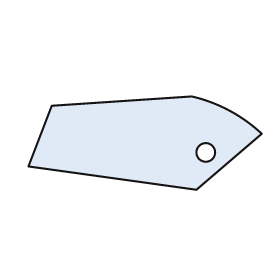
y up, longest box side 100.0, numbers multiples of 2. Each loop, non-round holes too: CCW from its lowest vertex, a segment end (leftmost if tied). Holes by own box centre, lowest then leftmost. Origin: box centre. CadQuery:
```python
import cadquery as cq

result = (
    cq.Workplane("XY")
    .moveTo(22.0, -20.0)
    .lineTo(50.0, 4.0)
    .threePointArc((36.0, 14.0), (20.0, 20.0))
    .lineTo(-40.0, 16.0)
    .lineTo(-50.0, -10.0)
    .close()
    .moveTo(26.0, -4.0)
    .circle(4.0)
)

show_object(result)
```